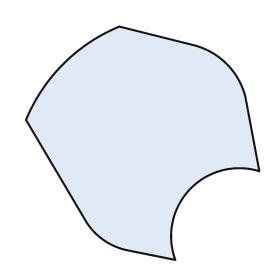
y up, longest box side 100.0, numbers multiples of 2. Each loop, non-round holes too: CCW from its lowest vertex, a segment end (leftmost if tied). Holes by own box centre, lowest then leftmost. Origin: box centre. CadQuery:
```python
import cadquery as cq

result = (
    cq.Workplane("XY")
    .moveTo(14.0, -50.0)
    .threePointArc((20.0, -20.0), (50.0, -12.0))
    .lineTo(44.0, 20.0)
    .threePointArc((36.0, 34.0), (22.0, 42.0))
    .lineTo(-10.0, 50.0)
    .threePointArc((-34.0, 34.0), (-50.0, 10.0))
    .lineTo(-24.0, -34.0)
    .threePointArc((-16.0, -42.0), (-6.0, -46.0))
    .close()
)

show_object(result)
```